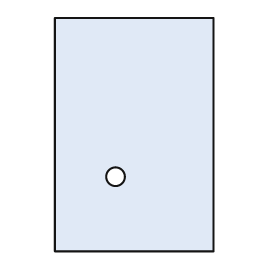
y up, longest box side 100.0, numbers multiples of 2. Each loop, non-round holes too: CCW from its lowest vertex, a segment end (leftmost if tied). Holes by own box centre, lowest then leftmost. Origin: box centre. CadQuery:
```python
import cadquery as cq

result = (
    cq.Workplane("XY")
    .moveTo(-34.0, -50.0)
    .lineTo(34.0, -50.0)
    .lineTo(34.0, 50.0)
    .lineTo(-34.0, 50.0)
    .close()
    .moveTo(-8.0, -18.0)
    .circle(4.0)
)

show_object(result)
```